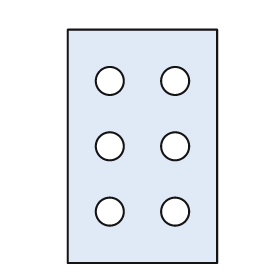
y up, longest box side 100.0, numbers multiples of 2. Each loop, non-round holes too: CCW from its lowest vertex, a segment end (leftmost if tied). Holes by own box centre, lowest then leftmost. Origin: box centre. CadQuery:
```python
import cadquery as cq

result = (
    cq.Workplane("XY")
    .moveTo(-32.0, -50.0)
    .lineTo(32.0, -50.0)
    .lineTo(32.0, 50.0)
    .lineTo(-32.0, 50.0)
    .close()
    .moveTo(-14.0, -28.0)
    .circle(6.0)
    .moveTo(14.0, -28.0)
    .circle(6.0)
    .moveTo(-14.0, 0.0)
    .circle(6.0)
    .moveTo(14.0, 0.0)
    .circle(6.0)
    .moveTo(-14.0, 28.0)
    .circle(6.0)
    .moveTo(14.0, 28.0)
    .circle(6.0)
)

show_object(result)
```